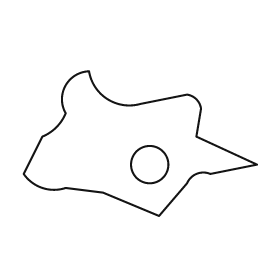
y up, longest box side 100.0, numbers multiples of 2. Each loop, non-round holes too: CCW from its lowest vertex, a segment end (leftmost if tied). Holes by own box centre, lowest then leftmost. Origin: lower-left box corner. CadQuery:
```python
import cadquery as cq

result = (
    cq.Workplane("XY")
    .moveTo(58.0, 0.0)
    .lineTo(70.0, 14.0)
    .threePointArc((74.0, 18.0), (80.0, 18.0))
    .lineTo(100.0, 22.0)
    .lineTo(74.0, 34.0)
    .lineTo(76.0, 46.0)
    .threePointArc((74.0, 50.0), (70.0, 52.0))
    .lineTo(50.0, 48.0)
    .threePointArc((36.0, 50.0), (28.0, 62.0))
    .threePointArc((18.0, 56.0), (18.0, 44.0))
    .threePointArc((14.0, 38.0), (8.0, 34.0))
    .lineTo(0.0, 18.0)
    .threePointArc((8.0, 12.0), (18.0, 12.0))
    .lineTo(34.0, 10.0)
    .close()
    .moveTo(54.0, 22.0)
    .circle(8.0)
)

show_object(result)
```